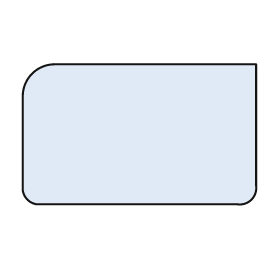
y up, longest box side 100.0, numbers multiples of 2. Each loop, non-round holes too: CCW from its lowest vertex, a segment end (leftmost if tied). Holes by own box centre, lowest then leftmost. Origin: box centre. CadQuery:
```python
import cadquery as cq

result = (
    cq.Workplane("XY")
    .moveTo(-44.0, -30.0)
    .lineTo(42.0, -30.0)
    .threePointArc((48.0, -28.0), (50.0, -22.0))
    .lineTo(50.0, 30.0)
    .lineTo(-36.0, 30.0)
    .threePointArc((-46.0, 26.0), (-50.0, 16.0))
    .lineTo(-50.0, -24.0)
    .threePointArc((-48.0, -28.0), (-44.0, -30.0))
    .close()
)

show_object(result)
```